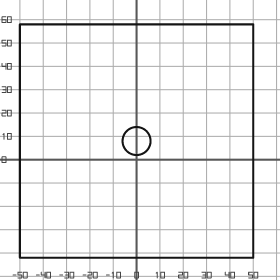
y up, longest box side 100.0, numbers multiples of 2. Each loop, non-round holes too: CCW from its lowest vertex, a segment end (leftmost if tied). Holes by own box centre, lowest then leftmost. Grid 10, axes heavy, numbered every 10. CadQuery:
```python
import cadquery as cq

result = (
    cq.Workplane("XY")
    .moveTo(-50.0, -42.0)
    .lineTo(50.0, -42.0)
    .lineTo(50.0, 58.0)
    .lineTo(-50.0, 58.0)
    .close()
    .moveTo(0.0, 8.0)
    .circle(6.0)
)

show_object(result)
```